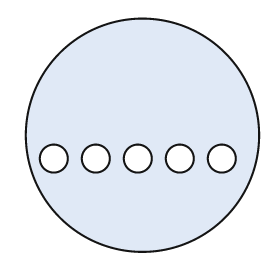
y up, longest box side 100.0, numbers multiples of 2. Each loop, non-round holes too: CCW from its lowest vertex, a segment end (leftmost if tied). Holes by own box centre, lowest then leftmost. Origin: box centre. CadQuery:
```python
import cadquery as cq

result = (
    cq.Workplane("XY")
    .moveTo(0.0, 0.0)
    .circle(50.0)
    .moveTo(-38.0, -10.0)
    .circle(6.0)
    .moveTo(-20.0, -10.0)
    .circle(6.0)
    .moveTo(-2.0, -10.0)
    .circle(6.0)
    .moveTo(16.0, -10.0)
    .circle(6.0)
    .moveTo(34.0, -10.0)
    .circle(6.0)
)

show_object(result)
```